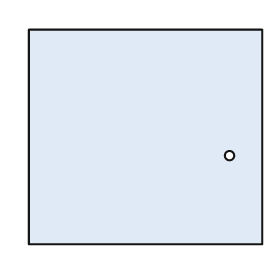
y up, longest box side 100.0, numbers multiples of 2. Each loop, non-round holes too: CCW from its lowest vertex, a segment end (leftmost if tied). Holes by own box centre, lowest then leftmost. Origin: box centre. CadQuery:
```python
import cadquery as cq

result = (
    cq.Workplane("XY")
    .moveTo(-50.0, -46.0)
    .lineTo(50.0, -46.0)
    .lineTo(50.0, 46.0)
    .lineTo(-50.0, 46.0)
    .close()
    .moveTo(36.0, -8.0)
    .circle(2.0)
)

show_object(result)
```